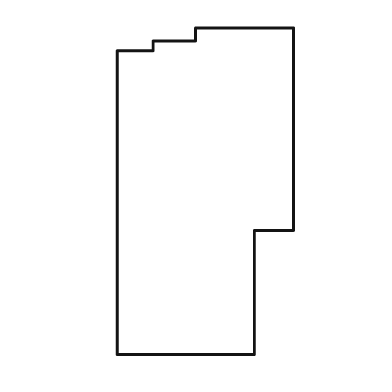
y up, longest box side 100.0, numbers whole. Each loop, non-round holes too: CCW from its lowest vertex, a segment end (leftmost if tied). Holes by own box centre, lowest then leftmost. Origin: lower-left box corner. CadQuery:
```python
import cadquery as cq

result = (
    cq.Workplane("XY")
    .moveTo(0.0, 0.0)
    .lineTo(42.0, 0.0)
    .lineTo(42.0, 38.0)
    .lineTo(54.0, 38.0)
    .lineTo(54.0, 100.0)
    .lineTo(24.0, 100.0)
    .lineTo(24.0, 96.0)
    .lineTo(11.0, 96.0)
    .lineTo(11.0, 93.0)
    .lineTo(0.0, 93.0)
    .close()
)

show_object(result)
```